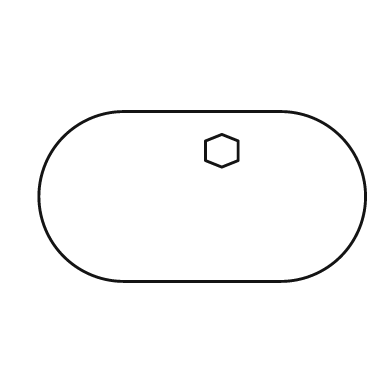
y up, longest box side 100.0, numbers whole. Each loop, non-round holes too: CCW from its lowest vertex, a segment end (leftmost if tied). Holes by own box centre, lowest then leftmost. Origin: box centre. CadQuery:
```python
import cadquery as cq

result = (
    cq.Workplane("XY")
    .moveTo(-24.0, -26.0)
    .lineTo(24.0, -26.0)
    .threePointArc((50.0, 0.0), (24.0, 26.0))
    .lineTo(-24.0, 26.0)
    .threePointArc((-50.0, 0.0), (-24.0, -26.0))
    .close()
    .moveTo(6.0, 9.0)
    .lineTo(11.0, 11.0)
    .lineTo(11.0, 17.0)
    .lineTo(6.0, 19.0)
    .lineTo(1.0, 17.0)
    .lineTo(1.0, 11.0)
    .close()
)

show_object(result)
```